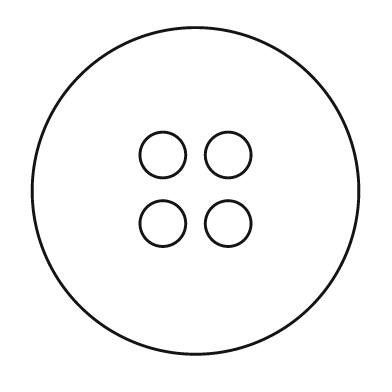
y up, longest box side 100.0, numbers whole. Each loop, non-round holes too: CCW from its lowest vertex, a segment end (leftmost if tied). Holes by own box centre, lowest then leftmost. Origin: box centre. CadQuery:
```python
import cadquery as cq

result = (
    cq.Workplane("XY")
    .moveTo(0.0, 0.0)
    .circle(50.0)
    .moveTo(-10.0, -10.0)
    .circle(7.0)
    .moveTo(10.0, -10.0)
    .circle(7.0)
    .moveTo(-10.0, 11.0)
    .circle(7.0)
    .moveTo(10.0, 11.0)
    .circle(7.0)
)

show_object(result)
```